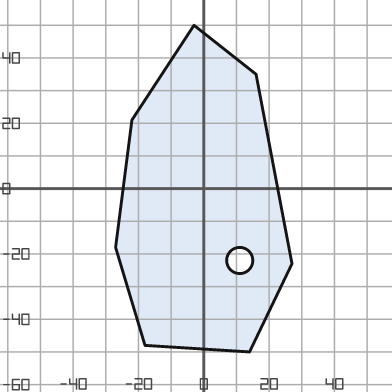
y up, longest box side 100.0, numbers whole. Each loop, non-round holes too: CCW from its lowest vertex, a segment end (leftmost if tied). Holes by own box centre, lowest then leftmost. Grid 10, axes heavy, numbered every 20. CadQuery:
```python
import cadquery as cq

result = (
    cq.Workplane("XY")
    .moveTo(14.0, -50.0)
    .lineTo(27.0, -23.0)
    .lineTo(16.0, 35.0)
    .lineTo(-3.0, 50.0)
    .lineTo(-22.0, 21.0)
    .lineTo(-27.0, -18.0)
    .lineTo(-18.0, -48.0)
    .close()
    .moveTo(11.0, -22.0)
    .circle(4.0)
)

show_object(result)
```